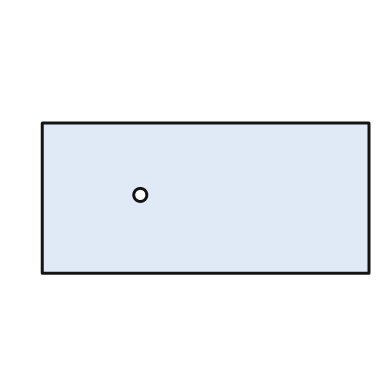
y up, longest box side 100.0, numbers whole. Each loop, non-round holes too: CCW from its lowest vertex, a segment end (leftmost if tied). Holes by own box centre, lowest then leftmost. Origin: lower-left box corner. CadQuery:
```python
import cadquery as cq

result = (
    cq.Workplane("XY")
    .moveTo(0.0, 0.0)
    .lineTo(100.0, 0.0)
    .lineTo(100.0, 46.0)
    .lineTo(0.0, 46.0)
    .close()
    .moveTo(30.0, 24.0)
    .circle(2.0)
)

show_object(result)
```